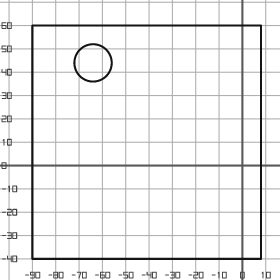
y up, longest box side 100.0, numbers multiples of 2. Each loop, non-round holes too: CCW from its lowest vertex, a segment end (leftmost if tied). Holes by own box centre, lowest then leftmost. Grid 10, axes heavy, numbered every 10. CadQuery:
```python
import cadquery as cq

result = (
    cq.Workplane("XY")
    .moveTo(-90.0, -40.0)
    .lineTo(8.0, -40.0)
    .lineTo(8.0, 60.0)
    .lineTo(-90.0, 60.0)
    .close()
    .moveTo(-64.0, 44.0)
    .circle(8.0)
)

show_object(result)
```